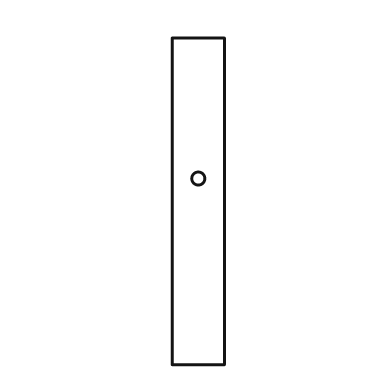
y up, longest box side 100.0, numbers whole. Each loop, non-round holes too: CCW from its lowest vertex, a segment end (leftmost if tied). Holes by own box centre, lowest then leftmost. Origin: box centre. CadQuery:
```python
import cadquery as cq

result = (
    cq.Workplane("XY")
    .moveTo(-8.0, -50.0)
    .lineTo(8.0, -50.0)
    .lineTo(8.0, 50.0)
    .lineTo(-8.0, 50.0)
    .close()
    .moveTo(0.0, 7.0)
    .circle(2.0)
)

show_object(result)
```